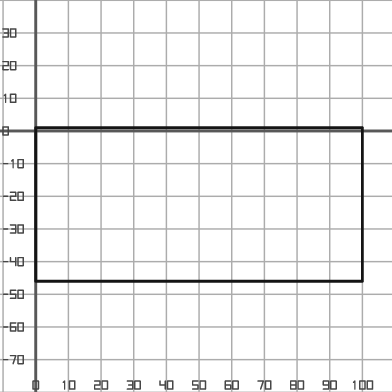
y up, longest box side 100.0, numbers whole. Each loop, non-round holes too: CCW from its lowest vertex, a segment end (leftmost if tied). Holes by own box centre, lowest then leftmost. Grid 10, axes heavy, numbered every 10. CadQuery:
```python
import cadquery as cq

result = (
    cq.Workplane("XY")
    .moveTo(0.0, -46.0)
    .lineTo(100.0, -46.0)
    .lineTo(100.0, 1.0)
    .lineTo(0.0, 1.0)
    .close()
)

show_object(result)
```